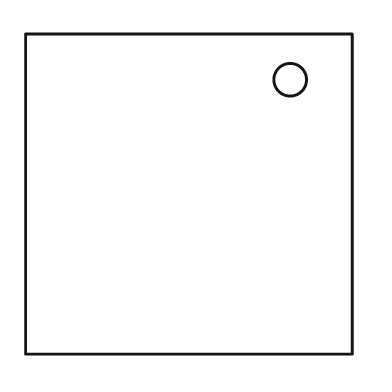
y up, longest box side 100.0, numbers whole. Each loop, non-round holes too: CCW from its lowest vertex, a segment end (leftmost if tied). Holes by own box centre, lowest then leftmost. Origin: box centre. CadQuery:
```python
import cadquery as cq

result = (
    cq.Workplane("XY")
    .moveTo(-50.0, -49.0)
    .lineTo(50.0, -49.0)
    .lineTo(50.0, 49.0)
    .lineTo(-50.0, 49.0)
    .close()
    .moveTo(31.0, 35.0)
    .circle(5.0)
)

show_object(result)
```